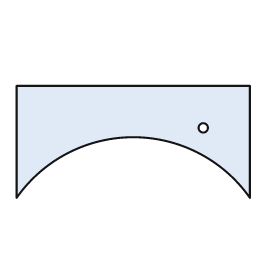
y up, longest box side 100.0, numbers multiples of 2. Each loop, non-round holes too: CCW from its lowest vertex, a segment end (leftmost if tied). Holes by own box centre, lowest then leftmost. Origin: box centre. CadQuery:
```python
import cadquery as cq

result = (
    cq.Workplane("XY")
    .moveTo(-50.0, -24.0)
    .threePointArc((0.0, 2.0), (50.0, -24.0))
    .lineTo(50.0, 24.0)
    .lineTo(-50.0, 24.0)
    .close()
    .moveTo(30.0, 6.0)
    .circle(2.0)
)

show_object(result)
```